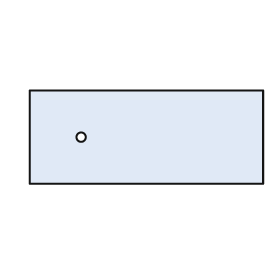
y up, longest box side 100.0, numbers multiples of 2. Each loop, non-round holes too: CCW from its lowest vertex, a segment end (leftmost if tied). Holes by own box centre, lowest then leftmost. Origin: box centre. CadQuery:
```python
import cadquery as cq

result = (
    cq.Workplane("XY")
    .moveTo(-50.0, -20.0)
    .lineTo(50.0, -20.0)
    .lineTo(50.0, 20.0)
    .lineTo(-50.0, 20.0)
    .close()
    .moveTo(-28.0, 0.0)
    .circle(2.0)
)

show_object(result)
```